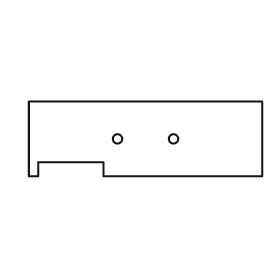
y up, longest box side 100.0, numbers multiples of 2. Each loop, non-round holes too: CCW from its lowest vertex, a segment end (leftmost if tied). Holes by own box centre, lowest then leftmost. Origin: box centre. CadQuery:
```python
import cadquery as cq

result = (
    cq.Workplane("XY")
    .moveTo(-50.0, -16.0)
    .lineTo(-46.0, -16.0)
    .lineTo(-46.0, -10.0)
    .lineTo(-18.0, -10.0)
    .lineTo(-18.0, -16.0)
    .lineTo(50.0, -16.0)
    .lineTo(50.0, 16.0)
    .lineTo(-50.0, 16.0)
    .close()
    .moveTo(-12.0, 0.0)
    .circle(2.0)
    .moveTo(12.0, 0.0)
    .circle(2.0)
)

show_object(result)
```